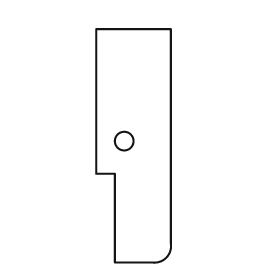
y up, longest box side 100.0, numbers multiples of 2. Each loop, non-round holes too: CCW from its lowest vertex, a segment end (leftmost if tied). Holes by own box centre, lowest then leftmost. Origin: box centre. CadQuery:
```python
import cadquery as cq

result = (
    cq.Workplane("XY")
    .moveTo(-8.0, -50.0)
    .lineTo(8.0, -50.0)
    .threePointArc((14.0, -48.0), (16.0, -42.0))
    .lineTo(16.0, 50.0)
    .lineTo(-16.0, 50.0)
    .lineTo(-16.0, -12.0)
    .lineTo(-8.0, -12.0)
    .close()
    .moveTo(-4.0, 2.0)
    .circle(4.0)
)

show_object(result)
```